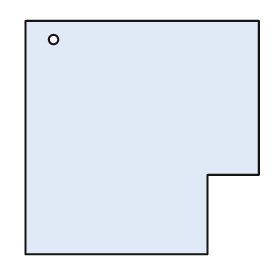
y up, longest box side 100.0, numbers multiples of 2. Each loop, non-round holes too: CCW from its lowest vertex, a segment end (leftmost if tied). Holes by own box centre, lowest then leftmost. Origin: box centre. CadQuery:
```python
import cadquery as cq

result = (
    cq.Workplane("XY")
    .moveTo(-50.0, -50.0)
    .lineTo(28.0, -50.0)
    .lineTo(28.0, -16.0)
    .lineTo(50.0, -16.0)
    .lineTo(50.0, 50.0)
    .lineTo(-50.0, 50.0)
    .close()
    .moveTo(-38.0, 42.0)
    .circle(2.0)
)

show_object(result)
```